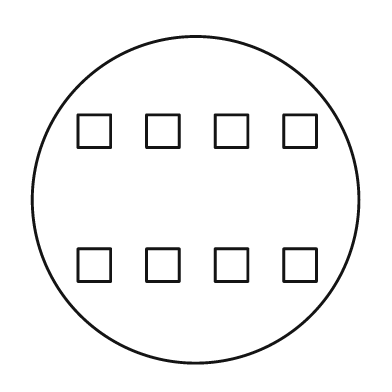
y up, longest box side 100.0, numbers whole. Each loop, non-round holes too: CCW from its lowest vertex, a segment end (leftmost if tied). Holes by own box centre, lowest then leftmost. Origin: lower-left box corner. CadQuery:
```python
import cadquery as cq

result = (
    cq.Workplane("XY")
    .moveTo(50.0, 50.0)
    .circle(50.0)
    .moveTo(14.0, 25.0)
    .lineTo(24.0, 25.0)
    .lineTo(24.0, 35.0)
    .lineTo(14.0, 35.0)
    .close()
    .moveTo(35.0, 25.0)
    .lineTo(45.0, 25.0)
    .lineTo(45.0, 35.0)
    .lineTo(35.0, 35.0)
    .close()
    .moveTo(56.0, 25.0)
    .lineTo(66.0, 25.0)
    .lineTo(66.0, 35.0)
    .lineTo(56.0, 35.0)
    .close()
    .moveTo(77.0, 25.0)
    .lineTo(87.0, 25.0)
    .lineTo(87.0, 35.0)
    .lineTo(77.0, 35.0)
    .close()
    .moveTo(14.0, 66.0)
    .lineTo(24.0, 66.0)
    .lineTo(24.0, 76.0)
    .lineTo(14.0, 76.0)
    .close()
    .moveTo(35.0, 66.0)
    .lineTo(45.0, 66.0)
    .lineTo(45.0, 76.0)
    .lineTo(35.0, 76.0)
    .close()
    .moveTo(56.0, 66.0)
    .lineTo(66.0, 66.0)
    .lineTo(66.0, 76.0)
    .lineTo(56.0, 76.0)
    .close()
    .moveTo(77.0, 66.0)
    .lineTo(87.0, 66.0)
    .lineTo(87.0, 76.0)
    .lineTo(77.0, 76.0)
    .close()
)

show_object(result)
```